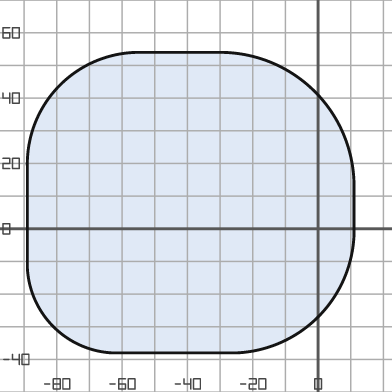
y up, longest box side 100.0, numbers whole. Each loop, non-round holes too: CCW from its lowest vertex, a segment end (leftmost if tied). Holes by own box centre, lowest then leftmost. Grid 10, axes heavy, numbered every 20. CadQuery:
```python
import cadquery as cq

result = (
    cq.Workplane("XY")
    .moveTo(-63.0, -38.0)
    .lineTo(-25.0, -38.0)
    .threePointArc((0.0, -27.0), (11.0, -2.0))
    .lineTo(11.0, 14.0)
    .threePointArc((-1.0, 42.0), (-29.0, 54.0))
    .lineTo(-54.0, 54.0)
    .threePointArc((-79.0, 44.0), (-89.0, 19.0))
    .lineTo(-89.0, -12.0)
    .threePointArc((-81.0, -30.0), (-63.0, -38.0))
    .close()
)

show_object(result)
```